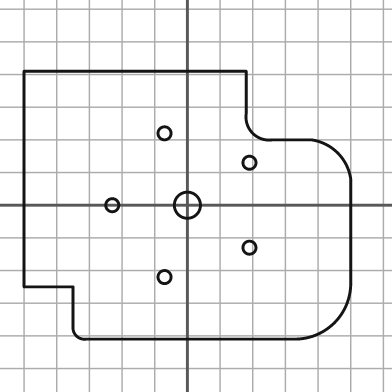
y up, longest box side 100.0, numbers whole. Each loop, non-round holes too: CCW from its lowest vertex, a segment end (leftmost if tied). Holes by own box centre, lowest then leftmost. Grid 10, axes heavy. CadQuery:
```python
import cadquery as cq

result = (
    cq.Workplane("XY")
    .moveTo(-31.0, -41.0)
    .lineTo(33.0, -41.0)
    .threePointArc((45.0, -36.0), (50.0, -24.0))
    .lineTo(50.0, 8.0)
    .threePointArc((46.0, 16.0), (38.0, 20.0))
    .lineTo(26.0, 20.0)
    .threePointArc((20.0, 22.0), (18.0, 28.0))
    .lineTo(18.0, 41.0)
    .lineTo(-50.0, 41.0)
    .lineTo(-50.0, -25.0)
    .lineTo(-35.0, -25.0)
    .lineTo(-35.0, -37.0)
    .threePointArc((-34.0, -40.0), (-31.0, -41.0))
    .close()
    .moveTo(-7.0, -22.0)
    .circle(2.0)
    .moveTo(19.0, -13.0)
    .circle(2.0)
    .moveTo(-23.0, 0.0)
    .circle(2.0)
    .moveTo(0.0, 0.0)
    .circle(4.0)
    .moveTo(19.0, 13.0)
    .circle(2.0)
    .moveTo(-7.0, 22.0)
    .circle(2.0)
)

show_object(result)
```